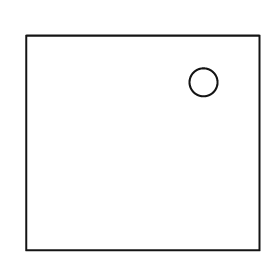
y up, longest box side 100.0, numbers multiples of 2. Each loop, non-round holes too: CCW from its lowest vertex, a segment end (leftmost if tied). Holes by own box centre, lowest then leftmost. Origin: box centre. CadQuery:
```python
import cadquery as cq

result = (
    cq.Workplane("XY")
    .moveTo(-50.0, -46.0)
    .lineTo(50.0, -46.0)
    .lineTo(50.0, 46.0)
    .lineTo(-50.0, 46.0)
    .close()
    .moveTo(26.0, 26.0)
    .circle(6.0)
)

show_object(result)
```